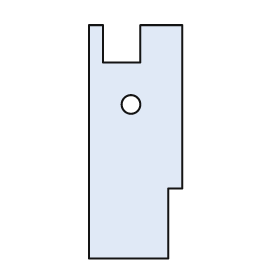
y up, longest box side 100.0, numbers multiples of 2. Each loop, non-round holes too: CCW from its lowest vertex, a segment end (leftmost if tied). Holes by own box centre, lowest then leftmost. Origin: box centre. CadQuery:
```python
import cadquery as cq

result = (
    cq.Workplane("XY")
    .moveTo(-20.0, -50.0)
    .lineTo(14.0, -50.0)
    .lineTo(14.0, -20.0)
    .lineTo(20.0, -20.0)
    .lineTo(20.0, 50.0)
    .lineTo(2.0, 50.0)
    .lineTo(2.0, 34.0)
    .lineTo(-14.0, 34.0)
    .lineTo(-14.0, 50.0)
    .lineTo(-20.0, 50.0)
    .close()
    .moveTo(-2.0, 16.0)
    .circle(4.0)
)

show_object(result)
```